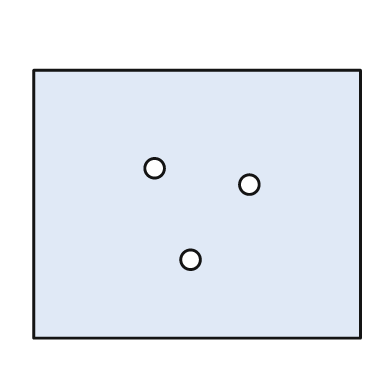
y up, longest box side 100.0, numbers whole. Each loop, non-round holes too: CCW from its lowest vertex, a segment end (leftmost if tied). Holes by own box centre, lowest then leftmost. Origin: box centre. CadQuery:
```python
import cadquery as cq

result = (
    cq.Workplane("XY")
    .moveTo(-50.0, -41.0)
    .lineTo(50.0, -41.0)
    .lineTo(50.0, 41.0)
    .lineTo(-50.0, 41.0)
    .close()
    .moveTo(-2.0, -17.0)
    .circle(3.0)
    .moveTo(16.0, 6.0)
    .circle(3.0)
    .moveTo(-13.0, 11.0)
    .circle(3.0)
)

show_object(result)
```